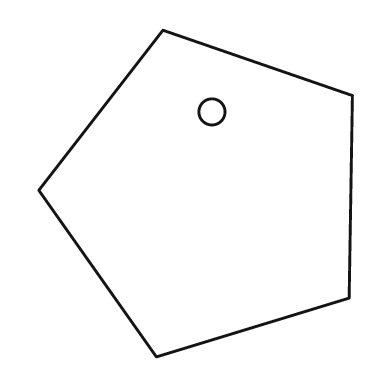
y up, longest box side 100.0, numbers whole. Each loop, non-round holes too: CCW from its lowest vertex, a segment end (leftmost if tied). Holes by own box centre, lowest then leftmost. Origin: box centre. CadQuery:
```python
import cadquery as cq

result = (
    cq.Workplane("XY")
    .moveTo(-12.0, -50.0)
    .lineTo(47.0, -32.0)
    .lineTo(48.0, 30.0)
    .lineTo(-10.0, 50.0)
    .lineTo(-48.0, 1.0)
    .close()
    .moveTo(5.0, 25.0)
    .circle(4.0)
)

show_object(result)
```